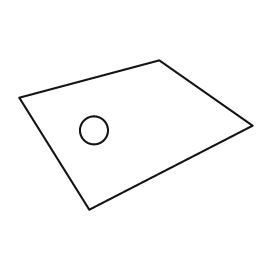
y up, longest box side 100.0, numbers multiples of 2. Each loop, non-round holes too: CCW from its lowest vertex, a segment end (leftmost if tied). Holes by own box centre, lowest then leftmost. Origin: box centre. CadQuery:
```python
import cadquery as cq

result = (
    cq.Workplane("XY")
    .moveTo(-20.0, -32.0)
    .lineTo(50.0, 4.0)
    .lineTo(10.0, 32.0)
    .lineTo(-50.0, 16.0)
    .close()
    .moveTo(-18.0, 2.0)
    .circle(6.0)
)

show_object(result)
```